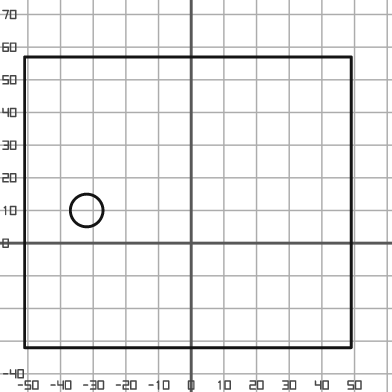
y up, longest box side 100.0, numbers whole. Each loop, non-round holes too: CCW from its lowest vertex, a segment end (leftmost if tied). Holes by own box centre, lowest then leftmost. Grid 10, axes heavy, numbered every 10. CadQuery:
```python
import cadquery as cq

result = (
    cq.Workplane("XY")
    .moveTo(-51.0, -32.0)
    .lineTo(49.0, -32.0)
    .lineTo(49.0, 57.0)
    .lineTo(-51.0, 57.0)
    .close()
    .moveTo(-32.0, 10.0)
    .circle(5.0)
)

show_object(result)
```